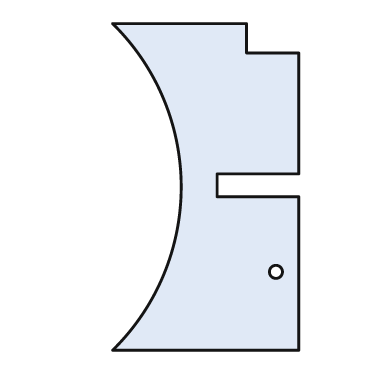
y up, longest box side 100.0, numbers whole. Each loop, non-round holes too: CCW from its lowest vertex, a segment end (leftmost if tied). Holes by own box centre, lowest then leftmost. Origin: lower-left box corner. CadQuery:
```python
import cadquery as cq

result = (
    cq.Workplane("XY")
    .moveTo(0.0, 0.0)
    .lineTo(57.0, 0.0)
    .lineTo(57.0, 47.0)
    .lineTo(32.0, 47.0)
    .lineTo(32.0, 54.0)
    .lineTo(57.0, 54.0)
    .lineTo(57.0, 91.0)
    .lineTo(41.0, 91.0)
    .lineTo(41.0, 100.0)
    .lineTo(0.0, 100.0)
    .threePointArc((21.0, 50.0), (0.0, 0.0))
    .close()
    .moveTo(50.0, 24.0)
    .circle(2.0)
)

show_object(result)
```